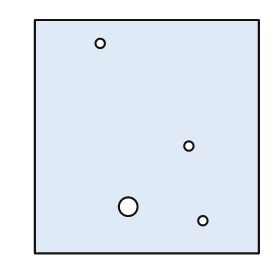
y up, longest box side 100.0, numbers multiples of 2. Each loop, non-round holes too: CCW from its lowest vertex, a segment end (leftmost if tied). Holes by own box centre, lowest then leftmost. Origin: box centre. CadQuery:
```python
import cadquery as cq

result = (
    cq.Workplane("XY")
    .moveTo(-48.0, -50.0)
    .lineTo(48.0, -50.0)
    .lineTo(48.0, 50.0)
    .lineTo(-48.0, 50.0)
    .close()
    .moveTo(24.0, -36.0)
    .circle(2.0)
    .moveTo(-8.0, -30.0)
    .circle(4.0)
    .moveTo(18.0, -4.0)
    .circle(2.0)
    .moveTo(-20.0, 40.0)
    .circle(2.0)
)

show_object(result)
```